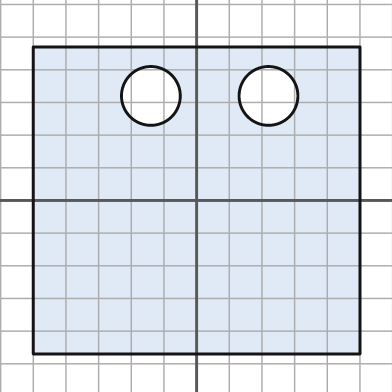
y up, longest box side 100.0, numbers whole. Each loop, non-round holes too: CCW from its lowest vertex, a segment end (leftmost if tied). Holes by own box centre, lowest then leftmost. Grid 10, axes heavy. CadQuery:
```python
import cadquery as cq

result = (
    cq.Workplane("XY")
    .moveTo(-50.0, -47.0)
    .lineTo(50.0, -47.0)
    .lineTo(50.0, 47.0)
    .lineTo(-50.0, 47.0)
    .close()
    .moveTo(-14.0, 32.0)
    .circle(9.0)
    .moveTo(22.0, 32.0)
    .circle(9.0)
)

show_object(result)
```